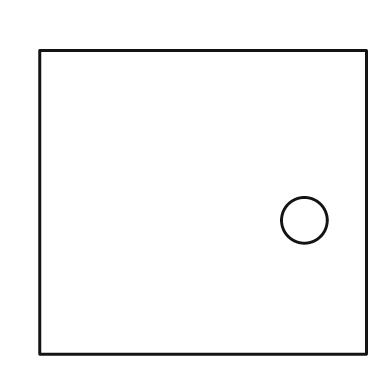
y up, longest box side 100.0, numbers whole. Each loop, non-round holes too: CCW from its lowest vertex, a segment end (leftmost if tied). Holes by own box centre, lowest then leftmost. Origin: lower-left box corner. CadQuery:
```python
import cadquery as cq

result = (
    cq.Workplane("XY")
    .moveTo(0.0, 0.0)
    .lineTo(100.0, 0.0)
    .lineTo(100.0, 93.0)
    .lineTo(0.0, 93.0)
    .close()
    .moveTo(81.0, 41.0)
    .circle(7.0)
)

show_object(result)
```